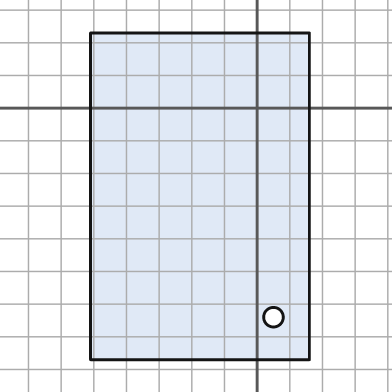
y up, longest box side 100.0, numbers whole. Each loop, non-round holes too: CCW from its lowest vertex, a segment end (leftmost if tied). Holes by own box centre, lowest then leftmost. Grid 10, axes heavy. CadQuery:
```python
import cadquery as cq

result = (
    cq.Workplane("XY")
    .moveTo(-51.0, -77.0)
    .lineTo(16.0, -77.0)
    .lineTo(16.0, 23.0)
    .lineTo(-51.0, 23.0)
    .close()
    .moveTo(5.0, -64.0)
    .circle(3.0)
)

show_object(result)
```